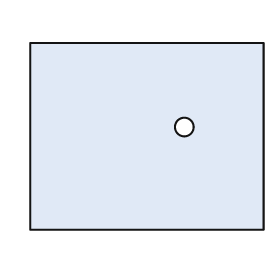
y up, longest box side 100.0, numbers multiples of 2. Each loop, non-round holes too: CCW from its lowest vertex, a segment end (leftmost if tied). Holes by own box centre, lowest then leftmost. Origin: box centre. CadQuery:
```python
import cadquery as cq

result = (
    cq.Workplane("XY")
    .moveTo(-50.0, -40.0)
    .lineTo(50.0, -40.0)
    .lineTo(50.0, 40.0)
    .lineTo(-50.0, 40.0)
    .close()
    .moveTo(16.0, 4.0)
    .circle(4.0)
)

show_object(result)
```